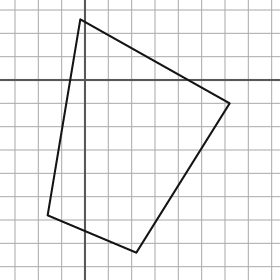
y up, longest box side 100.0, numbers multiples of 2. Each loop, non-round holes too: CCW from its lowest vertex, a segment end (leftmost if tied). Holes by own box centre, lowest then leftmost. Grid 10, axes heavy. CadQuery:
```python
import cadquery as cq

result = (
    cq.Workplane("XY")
    .moveTo(22.0, -74.0)
    .lineTo(62.0, -10.0)
    .lineTo(-2.0, 26.0)
    .lineTo(-16.0, -58.0)
    .close()
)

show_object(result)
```